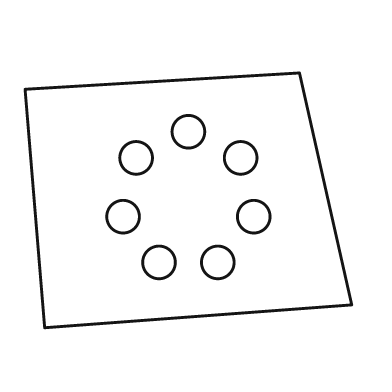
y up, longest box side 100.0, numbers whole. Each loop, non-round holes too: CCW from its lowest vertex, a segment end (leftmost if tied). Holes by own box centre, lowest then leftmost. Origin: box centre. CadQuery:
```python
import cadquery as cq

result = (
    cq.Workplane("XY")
    .moveTo(-44.0, -39.0)
    .lineTo(50.0, -32.0)
    .lineTo(34.0, 39.0)
    .lineTo(-50.0, 34.0)
    .close()
    .moveTo(-9.0, -19.0)
    .circle(5.0)
    .moveTo(9.0, -19.0)
    .circle(5.0)
    .moveTo(-20.0, -5.0)
    .circle(5.0)
    .moveTo(20.0, -5.0)
    .circle(5.0)
    .moveTo(-16.0, 13.0)
    .circle(5.0)
    .moveTo(16.0, 13.0)
    .circle(5.0)
    .moveTo(0.0, 21.0)
    .circle(5.0)
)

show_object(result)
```